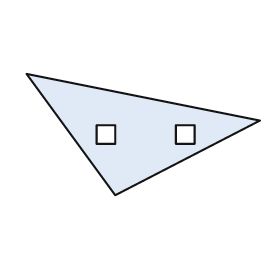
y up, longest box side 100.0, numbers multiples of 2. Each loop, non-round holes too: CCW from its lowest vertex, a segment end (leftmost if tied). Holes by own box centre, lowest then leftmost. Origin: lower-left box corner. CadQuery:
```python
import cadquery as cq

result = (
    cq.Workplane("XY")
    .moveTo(38.0, 0.0)
    .lineTo(100.0, 32.0)
    .lineTo(0.0, 52.0)
    .close()
    .moveTo(30.0, 22.0)
    .lineTo(38.0, 22.0)
    .lineTo(38.0, 30.0)
    .lineTo(30.0, 30.0)
    .close()
    .moveTo(64.0, 22.0)
    .lineTo(72.0, 22.0)
    .lineTo(72.0, 30.0)
    .lineTo(64.0, 30.0)
    .close()
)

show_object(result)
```